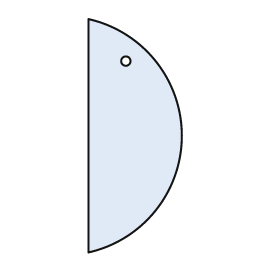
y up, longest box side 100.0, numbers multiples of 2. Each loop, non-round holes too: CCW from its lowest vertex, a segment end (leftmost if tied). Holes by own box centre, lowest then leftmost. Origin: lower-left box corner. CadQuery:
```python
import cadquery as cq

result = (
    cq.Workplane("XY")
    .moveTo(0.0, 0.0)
    .threePointArc((40.0, 50.0), (0.0, 100.0))
    .close()
    .moveTo(16.0, 82.0)
    .circle(2.0)
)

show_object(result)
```